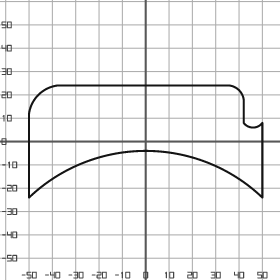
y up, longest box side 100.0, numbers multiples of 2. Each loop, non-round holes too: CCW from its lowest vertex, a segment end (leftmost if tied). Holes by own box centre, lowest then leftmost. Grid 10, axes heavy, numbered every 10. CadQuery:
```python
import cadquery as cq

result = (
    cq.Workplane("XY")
    .moveTo(-50.0, -24.0)
    .threePointArc((0.0, -4.0), (50.0, -24.0))
    .lineTo(50.0, 8.0)
    .threePointArc((46.0, 6.0), (42.0, 8.0))
    .lineTo(42.0, 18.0)
    .threePointArc((40.0, 22.0), (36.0, 24.0))
    .lineTo(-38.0, 24.0)
    .threePointArc((-46.0, 20.0), (-50.0, 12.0))
    .close()
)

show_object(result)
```